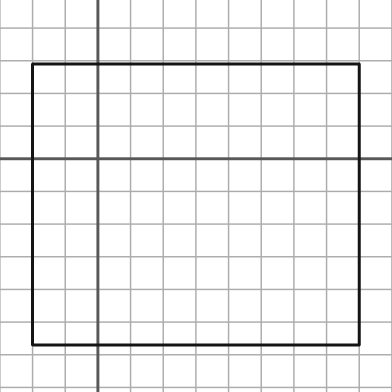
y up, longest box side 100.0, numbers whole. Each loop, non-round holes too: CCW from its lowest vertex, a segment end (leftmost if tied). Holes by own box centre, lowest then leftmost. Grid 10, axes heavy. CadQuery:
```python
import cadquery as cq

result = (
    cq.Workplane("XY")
    .moveTo(-20.0, -57.0)
    .lineTo(80.0, -57.0)
    .lineTo(80.0, 29.0)
    .lineTo(-20.0, 29.0)
    .close()
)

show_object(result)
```